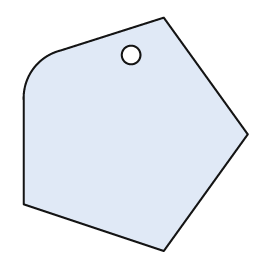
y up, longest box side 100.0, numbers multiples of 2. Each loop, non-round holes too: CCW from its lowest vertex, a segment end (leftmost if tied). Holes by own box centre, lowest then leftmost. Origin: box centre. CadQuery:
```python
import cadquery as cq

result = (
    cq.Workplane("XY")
    .moveTo(12.0, -50.0)
    .lineTo(48.0, 0.0)
    .lineTo(12.0, 50.0)
    .lineTo(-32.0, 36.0)
    .threePointArc((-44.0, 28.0), (-48.0, 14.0))
    .lineTo(-48.0, -30.0)
    .close()
    .moveTo(-2.0, 34.0)
    .circle(4.0)
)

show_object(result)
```